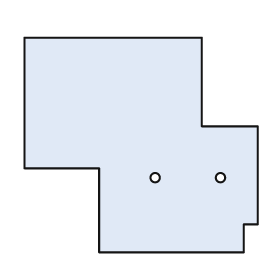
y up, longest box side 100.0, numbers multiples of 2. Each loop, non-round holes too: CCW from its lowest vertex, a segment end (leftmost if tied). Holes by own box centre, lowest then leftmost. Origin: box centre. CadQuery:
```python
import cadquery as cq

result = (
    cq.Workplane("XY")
    .moveTo(-18.0, -46.0)
    .lineTo(44.0, -46.0)
    .lineTo(44.0, -34.0)
    .lineTo(50.0, -34.0)
    .lineTo(50.0, 8.0)
    .lineTo(26.0, 8.0)
    .lineTo(26.0, 46.0)
    .lineTo(-50.0, 46.0)
    .lineTo(-50.0, -10.0)
    .lineTo(-18.0, -10.0)
    .close()
    .moveTo(6.0, -14.0)
    .circle(2.0)
    .moveTo(34.0, -14.0)
    .circle(2.0)
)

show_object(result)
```